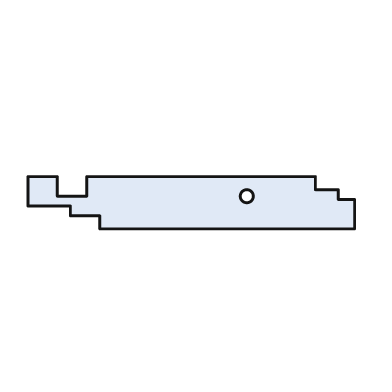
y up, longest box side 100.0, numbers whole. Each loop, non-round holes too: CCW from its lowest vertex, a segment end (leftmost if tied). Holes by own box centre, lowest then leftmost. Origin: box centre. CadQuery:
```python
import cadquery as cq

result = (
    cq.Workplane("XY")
    .moveTo(-28.0, -8.0)
    .lineTo(50.0, -8.0)
    .lineTo(50.0, 1.0)
    .lineTo(45.0, 1.0)
    .lineTo(45.0, 4.0)
    .lineTo(38.0, 4.0)
    .lineTo(38.0, 8.0)
    .lineTo(-32.0, 8.0)
    .lineTo(-32.0, 2.0)
    .lineTo(-41.0, 2.0)
    .lineTo(-41.0, 8.0)
    .lineTo(-50.0, 8.0)
    .lineTo(-50.0, -1.0)
    .lineTo(-37.0, -1.0)
    .lineTo(-37.0, -4.0)
    .lineTo(-28.0, -4.0)
    .close()
    .moveTo(17.0, 2.0)
    .circle(2.0)
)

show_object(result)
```